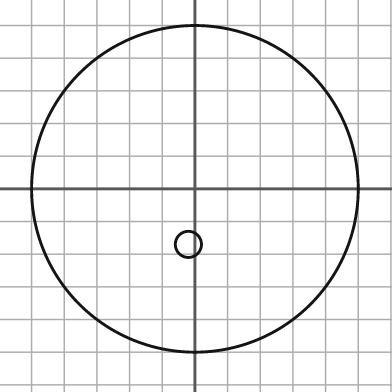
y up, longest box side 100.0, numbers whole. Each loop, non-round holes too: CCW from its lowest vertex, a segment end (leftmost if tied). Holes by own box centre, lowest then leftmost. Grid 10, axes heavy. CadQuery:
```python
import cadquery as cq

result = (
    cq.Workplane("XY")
    .moveTo(0.0, 0.0)
    .circle(50.0)
    .moveTo(-2.0, -17.0)
    .circle(4.0)
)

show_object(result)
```